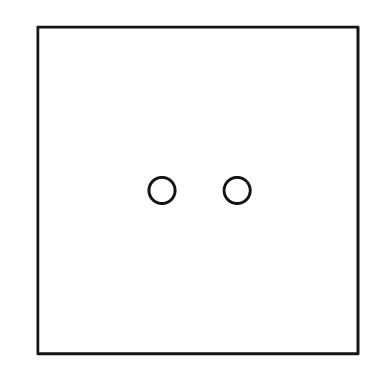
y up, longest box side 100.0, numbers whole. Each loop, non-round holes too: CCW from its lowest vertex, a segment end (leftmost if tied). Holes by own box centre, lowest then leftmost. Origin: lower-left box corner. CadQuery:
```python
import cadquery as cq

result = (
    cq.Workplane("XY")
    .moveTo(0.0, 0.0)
    .lineTo(98.0, 0.0)
    .lineTo(98.0, 100.0)
    .lineTo(0.0, 100.0)
    .close()
    .moveTo(38.0, 50.0)
    .circle(4.0)
    .moveTo(61.0, 50.0)
    .circle(4.0)
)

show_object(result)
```